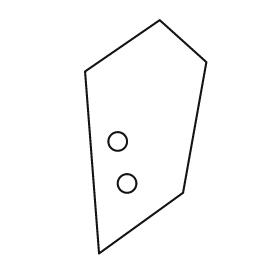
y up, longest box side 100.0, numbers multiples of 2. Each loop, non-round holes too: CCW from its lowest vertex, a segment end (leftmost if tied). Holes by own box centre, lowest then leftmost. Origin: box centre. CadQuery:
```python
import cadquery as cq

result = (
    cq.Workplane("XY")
    .moveTo(-20.0, -50.0)
    .lineTo(16.0, -24.0)
    .lineTo(26.0, 32.0)
    .lineTo(6.0, 50.0)
    .lineTo(-26.0, 28.0)
    .close()
    .moveTo(-8.0, -20.0)
    .circle(4.0)
    .moveTo(-12.0, -2.0)
    .circle(4.0)
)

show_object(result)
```